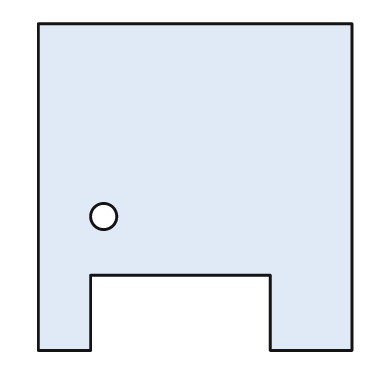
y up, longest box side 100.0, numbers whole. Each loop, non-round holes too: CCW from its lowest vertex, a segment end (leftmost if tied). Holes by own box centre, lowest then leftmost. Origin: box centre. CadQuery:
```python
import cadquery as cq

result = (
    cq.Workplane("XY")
    .moveTo(-48.0, -50.0)
    .lineTo(-32.0, -50.0)
    .lineTo(-32.0, -27.0)
    .lineTo(23.0, -27.0)
    .lineTo(23.0, -50.0)
    .lineTo(48.0, -50.0)
    .lineTo(48.0, 50.0)
    .lineTo(-48.0, 50.0)
    .close()
    .moveTo(-28.0, -9.0)
    .circle(4.0)
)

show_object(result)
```